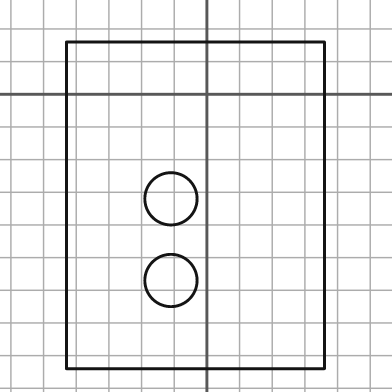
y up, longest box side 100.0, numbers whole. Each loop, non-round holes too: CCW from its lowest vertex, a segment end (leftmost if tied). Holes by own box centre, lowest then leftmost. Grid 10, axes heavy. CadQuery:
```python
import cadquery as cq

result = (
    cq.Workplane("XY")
    .moveTo(-43.0, -84.0)
    .lineTo(36.0, -84.0)
    .lineTo(36.0, 16.0)
    .lineTo(-43.0, 16.0)
    .close()
    .moveTo(-11.0, -57.0)
    .circle(8.0)
    .moveTo(-11.0, -32.0)
    .circle(8.0)
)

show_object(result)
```